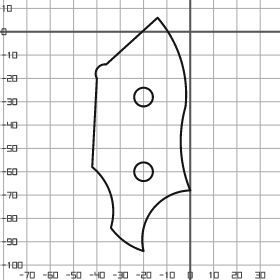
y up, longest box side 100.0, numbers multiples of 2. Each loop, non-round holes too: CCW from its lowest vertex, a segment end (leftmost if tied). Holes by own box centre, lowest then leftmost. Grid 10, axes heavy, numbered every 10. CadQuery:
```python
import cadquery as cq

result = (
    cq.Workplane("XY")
    .moveTo(-20.0, -94.0)
    .threePointArc((-16.0, -76.0), (0.0, -68.0))
    .threePointArc((-4.0, -50.0), (-2.0, -32.0))
    .threePointArc((-4.0, -12.0), (-14.0, 6.0))
    .lineTo(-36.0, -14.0)
    .threePointArc((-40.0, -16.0), (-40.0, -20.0))
    .lineTo(-42.0, -58.0)
    .threePointArc((-34.0, -70.0), (-34.0, -84.0))
    .threePointArc((-28.0, -90.0), (-20.0, -94.0))
    .close()
    .moveTo(-20.0, -60.0)
    .circle(4.0)
    .moveTo(-20.0, -28.0)
    .circle(4.0)
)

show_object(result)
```